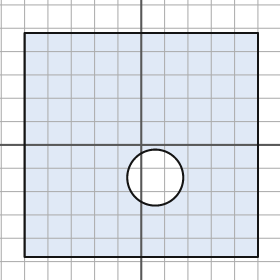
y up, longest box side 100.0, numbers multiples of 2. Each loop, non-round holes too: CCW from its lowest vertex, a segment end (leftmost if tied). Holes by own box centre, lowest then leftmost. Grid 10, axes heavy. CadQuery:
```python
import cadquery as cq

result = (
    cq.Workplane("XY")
    .moveTo(-50.0, -48.0)
    .lineTo(50.0, -48.0)
    .lineTo(50.0, 48.0)
    .lineTo(-50.0, 48.0)
    .close()
    .moveTo(6.0, -14.0)
    .circle(12.0)
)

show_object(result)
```